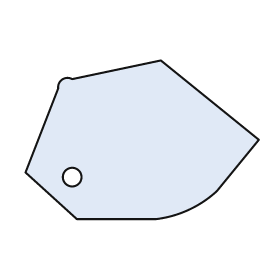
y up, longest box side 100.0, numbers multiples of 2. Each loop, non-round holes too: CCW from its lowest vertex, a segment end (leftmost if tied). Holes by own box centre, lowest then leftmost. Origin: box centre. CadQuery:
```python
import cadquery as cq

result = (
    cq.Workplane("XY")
    .moveTo(-28.0, -34.0)
    .lineTo(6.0, -34.0)
    .threePointArc((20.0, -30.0), (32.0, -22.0))
    .lineTo(50.0, 0.0)
    .lineTo(8.0, 34.0)
    .lineTo(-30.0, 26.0)
    .threePointArc((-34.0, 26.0), (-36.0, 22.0))
    .lineTo(-50.0, -14.0)
    .close()
    .moveTo(-30.0, -16.0)
    .circle(4.0)
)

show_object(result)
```